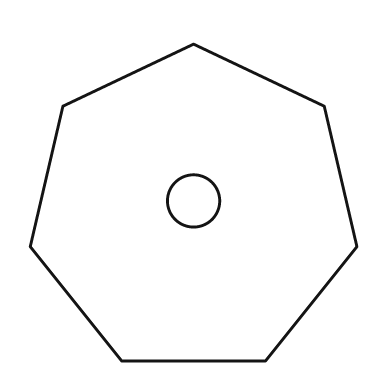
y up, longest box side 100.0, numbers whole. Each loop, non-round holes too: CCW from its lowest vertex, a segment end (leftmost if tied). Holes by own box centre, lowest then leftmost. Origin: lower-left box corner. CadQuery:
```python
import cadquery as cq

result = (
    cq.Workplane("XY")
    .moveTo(28.0, 0.0)
    .lineTo(72.0, 0.0)
    .lineTo(100.0, 35.0)
    .lineTo(90.0, 78.0)
    .lineTo(50.0, 97.0)
    .lineTo(10.0, 78.0)
    .lineTo(0.0, 35.0)
    .close()
    .moveTo(50.0, 49.0)
    .circle(8.0)
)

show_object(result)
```